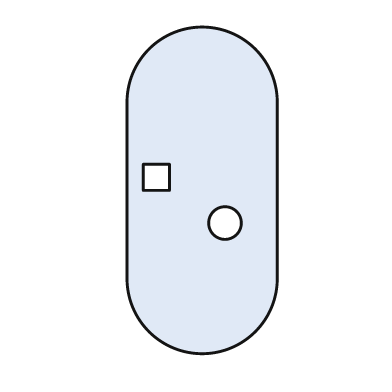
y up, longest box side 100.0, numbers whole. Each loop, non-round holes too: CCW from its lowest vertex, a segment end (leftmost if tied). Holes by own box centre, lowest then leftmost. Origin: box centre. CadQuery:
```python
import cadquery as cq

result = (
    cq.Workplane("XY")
    .moveTo(-23.0, -27.0)
    .threePointArc((0.0, -50.0), (23.0, -27.0))
    .lineTo(23.0, 27.0)
    .threePointArc((0.0, 50.0), (-23.0, 27.0))
    .close()
    .moveTo(7.0, -10.0)
    .circle(5.0)
    .moveTo(-18.0, 0.0)
    .lineTo(-10.0, 0.0)
    .lineTo(-10.0, 8.0)
    .lineTo(-18.0, 8.0)
    .close()
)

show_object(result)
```